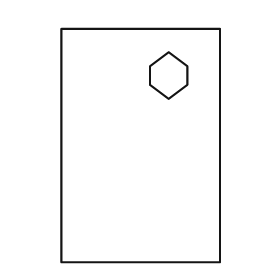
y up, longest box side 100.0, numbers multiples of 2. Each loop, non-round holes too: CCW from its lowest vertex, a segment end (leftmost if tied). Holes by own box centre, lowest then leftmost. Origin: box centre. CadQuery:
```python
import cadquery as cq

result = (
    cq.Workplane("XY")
    .moveTo(-34.0, -50.0)
    .lineTo(34.0, -50.0)
    .lineTo(34.0, 50.0)
    .lineTo(-34.0, 50.0)
    .close()
    .moveTo(12.0, 20.0)
    .lineTo(20.0, 26.0)
    .lineTo(20.0, 34.0)
    .lineTo(12.0, 40.0)
    .lineTo(4.0, 34.0)
    .lineTo(4.0, 26.0)
    .close()
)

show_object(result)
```